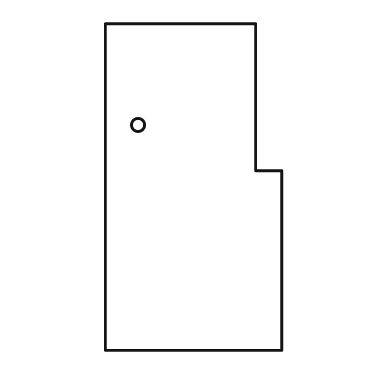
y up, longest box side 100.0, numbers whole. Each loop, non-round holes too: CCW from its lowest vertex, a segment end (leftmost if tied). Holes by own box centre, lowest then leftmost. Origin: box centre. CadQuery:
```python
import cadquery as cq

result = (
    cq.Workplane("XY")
    .moveTo(-27.0, -50.0)
    .lineTo(27.0, -50.0)
    .lineTo(27.0, 5.0)
    .lineTo(19.0, 5.0)
    .lineTo(19.0, 50.0)
    .lineTo(-27.0, 50.0)
    .close()
    .moveTo(-17.0, 19.0)
    .circle(2.0)
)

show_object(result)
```